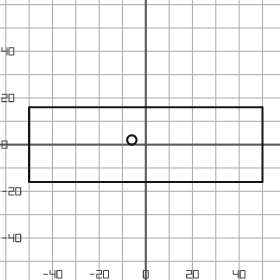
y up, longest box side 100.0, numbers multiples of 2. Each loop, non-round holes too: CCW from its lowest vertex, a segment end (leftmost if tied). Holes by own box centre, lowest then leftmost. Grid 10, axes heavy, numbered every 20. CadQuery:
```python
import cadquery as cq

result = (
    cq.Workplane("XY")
    .moveTo(-50.0, -16.0)
    .lineTo(50.0, -16.0)
    .lineTo(50.0, 16.0)
    .lineTo(-50.0, 16.0)
    .close()
    .moveTo(-6.0, 2.0)
    .circle(2.0)
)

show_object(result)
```